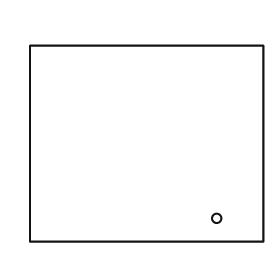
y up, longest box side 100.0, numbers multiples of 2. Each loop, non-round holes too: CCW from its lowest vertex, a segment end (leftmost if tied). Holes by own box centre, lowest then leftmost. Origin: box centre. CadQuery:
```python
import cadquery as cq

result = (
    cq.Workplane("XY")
    .moveTo(-50.0, -42.0)
    .lineTo(50.0, -42.0)
    .lineTo(50.0, 42.0)
    .lineTo(-50.0, 42.0)
    .close()
    .moveTo(30.0, -32.0)
    .circle(2.0)
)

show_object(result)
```